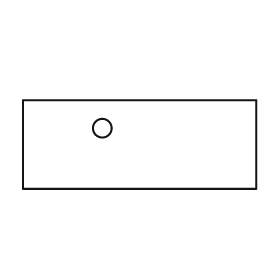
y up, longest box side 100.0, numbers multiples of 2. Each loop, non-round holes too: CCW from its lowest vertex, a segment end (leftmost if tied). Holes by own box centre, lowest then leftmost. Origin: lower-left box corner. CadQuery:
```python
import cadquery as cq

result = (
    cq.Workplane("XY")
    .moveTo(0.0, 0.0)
    .lineTo(100.0, 0.0)
    .lineTo(100.0, 38.0)
    .lineTo(0.0, 38.0)
    .close()
    .moveTo(34.0, 26.0)
    .circle(4.0)
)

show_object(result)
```